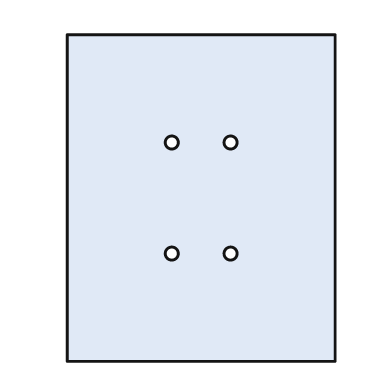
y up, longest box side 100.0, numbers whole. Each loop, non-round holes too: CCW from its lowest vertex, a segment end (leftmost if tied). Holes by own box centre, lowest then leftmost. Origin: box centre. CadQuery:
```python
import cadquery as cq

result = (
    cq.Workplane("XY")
    .moveTo(-41.0, -50.0)
    .lineTo(41.0, -50.0)
    .lineTo(41.0, 50.0)
    .lineTo(-41.0, 50.0)
    .close()
    .moveTo(-9.0, -17.0)
    .circle(2.0)
    .moveTo(9.0, -17.0)
    .circle(2.0)
    .moveTo(-9.0, 17.0)
    .circle(2.0)
    .moveTo(9.0, 17.0)
    .circle(2.0)
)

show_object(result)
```